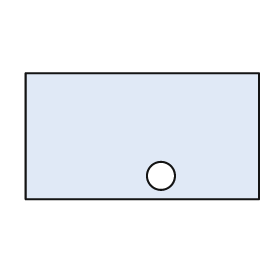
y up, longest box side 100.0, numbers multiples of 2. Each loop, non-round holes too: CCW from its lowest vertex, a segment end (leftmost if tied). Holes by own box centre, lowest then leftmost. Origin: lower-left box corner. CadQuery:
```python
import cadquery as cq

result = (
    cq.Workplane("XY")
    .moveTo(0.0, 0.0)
    .lineTo(100.0, 0.0)
    .lineTo(100.0, 54.0)
    .lineTo(0.0, 54.0)
    .close()
    .moveTo(58.0, 10.0)
    .circle(6.0)
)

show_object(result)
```